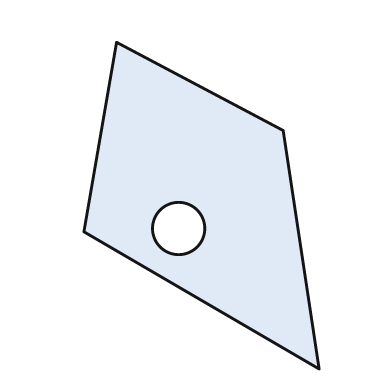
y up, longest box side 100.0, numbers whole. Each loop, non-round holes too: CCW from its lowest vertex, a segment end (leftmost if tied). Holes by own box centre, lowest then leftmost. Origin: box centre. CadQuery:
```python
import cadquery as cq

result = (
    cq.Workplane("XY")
    .moveTo(36.0, -50.0)
    .lineTo(25.0, 23.0)
    .lineTo(-26.0, 50.0)
    .lineTo(-36.0, -8.0)
    .close()
    .moveTo(-7.0, -7.0)
    .circle(8.0)
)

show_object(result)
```